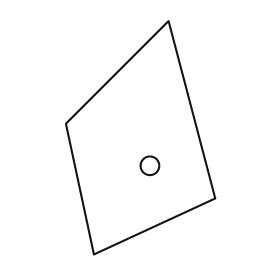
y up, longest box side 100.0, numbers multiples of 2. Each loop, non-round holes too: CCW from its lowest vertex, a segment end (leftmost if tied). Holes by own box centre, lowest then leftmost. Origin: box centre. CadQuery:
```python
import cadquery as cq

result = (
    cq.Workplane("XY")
    .moveTo(-20.0, -50.0)
    .lineTo(32.0, -26.0)
    .lineTo(12.0, 50.0)
    .lineTo(-32.0, 6.0)
    .close()
    .moveTo(4.0, -12.0)
    .circle(4.0)
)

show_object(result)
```